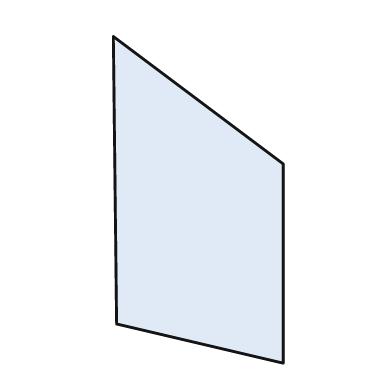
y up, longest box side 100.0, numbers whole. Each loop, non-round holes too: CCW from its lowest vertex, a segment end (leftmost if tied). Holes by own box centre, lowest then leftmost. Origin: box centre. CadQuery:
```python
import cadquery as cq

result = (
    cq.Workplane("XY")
    .moveTo(26.0, -50.0)
    .lineTo(26.0, 11.0)
    .lineTo(-26.0, 50.0)
    .lineTo(-25.0, -38.0)
    .close()
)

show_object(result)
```